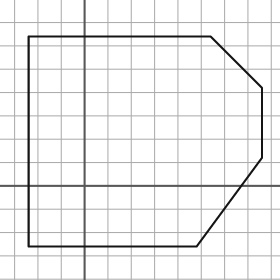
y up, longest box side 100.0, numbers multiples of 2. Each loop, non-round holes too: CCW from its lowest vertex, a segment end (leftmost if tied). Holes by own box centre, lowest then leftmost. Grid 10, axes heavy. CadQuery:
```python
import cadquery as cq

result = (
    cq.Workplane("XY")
    .moveTo(-24.0, -26.0)
    .lineTo(48.0, -26.0)
    .lineTo(76.0, 12.0)
    .lineTo(76.0, 42.0)
    .lineTo(54.0, 64.0)
    .lineTo(-24.0, 64.0)
    .close()
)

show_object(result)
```